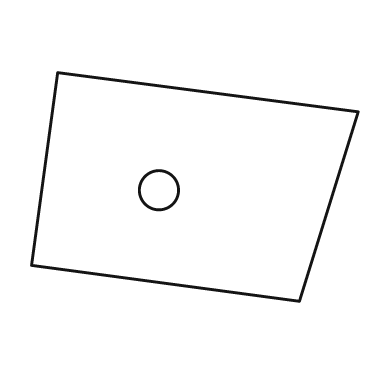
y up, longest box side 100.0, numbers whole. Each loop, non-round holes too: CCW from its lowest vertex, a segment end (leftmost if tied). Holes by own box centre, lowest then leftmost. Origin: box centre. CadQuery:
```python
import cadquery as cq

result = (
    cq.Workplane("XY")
    .moveTo(32.0, -35.0)
    .lineTo(50.0, 23.0)
    .lineTo(-42.0, 35.0)
    .lineTo(-50.0, -24.0)
    .close()
    .moveTo(-11.0, -1.0)
    .circle(6.0)
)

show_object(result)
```